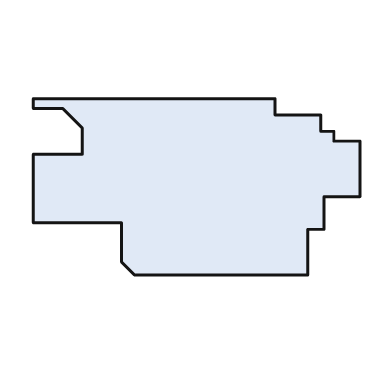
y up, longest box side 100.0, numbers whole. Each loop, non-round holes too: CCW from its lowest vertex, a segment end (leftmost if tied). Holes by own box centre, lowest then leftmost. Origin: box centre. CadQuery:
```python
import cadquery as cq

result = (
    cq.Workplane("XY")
    .moveTo(-19.0, -27.0)
    .lineTo(34.0, -27.0)
    .lineTo(34.0, -13.0)
    .lineTo(39.0, -13.0)
    .lineTo(39.0, -3.0)
    .lineTo(50.0, -3.0)
    .lineTo(50.0, 14.0)
    .lineTo(42.0, 14.0)
    .lineTo(42.0, 17.0)
    .lineTo(38.0, 17.0)
    .lineTo(38.0, 22.0)
    .lineTo(24.0, 22.0)
    .lineTo(24.0, 27.0)
    .lineTo(-50.0, 27.0)
    .lineTo(-50.0, 24.0)
    .lineTo(-41.0, 24.0)
    .lineTo(-35.0, 18.0)
    .lineTo(-35.0, 10.0)
    .lineTo(-50.0, 10.0)
    .lineTo(-50.0, -11.0)
    .lineTo(-23.0, -11.0)
    .lineTo(-23.0, -23.0)
    .close()
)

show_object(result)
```